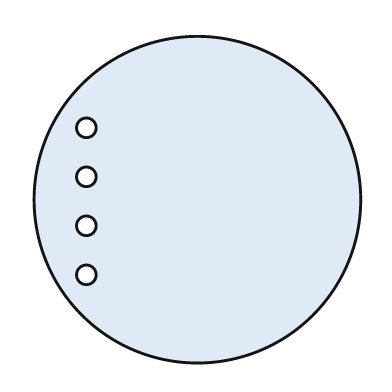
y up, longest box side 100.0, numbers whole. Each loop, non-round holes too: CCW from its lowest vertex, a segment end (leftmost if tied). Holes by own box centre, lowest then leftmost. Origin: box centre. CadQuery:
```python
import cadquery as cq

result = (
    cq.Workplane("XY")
    .moveTo(0.0, 0.0)
    .circle(50.0)
    .moveTo(-34.0, -23.0)
    .circle(3.0)
    .moveTo(-34.0, -8.0)
    .circle(3.0)
    .moveTo(-34.0, 7.0)
    .circle(3.0)
    .moveTo(-34.0, 22.0)
    .circle(3.0)
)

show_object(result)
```